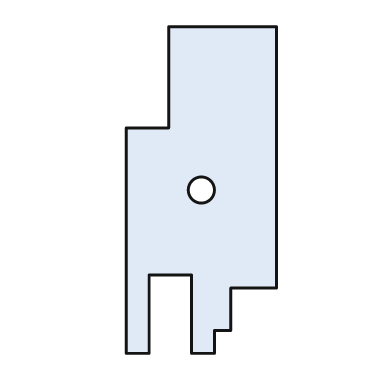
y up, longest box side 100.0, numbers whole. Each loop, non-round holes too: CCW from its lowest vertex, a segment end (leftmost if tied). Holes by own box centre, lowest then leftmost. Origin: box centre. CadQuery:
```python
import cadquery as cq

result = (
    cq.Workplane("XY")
    .moveTo(-23.0, -50.0)
    .lineTo(-16.0, -50.0)
    .lineTo(-16.0, -26.0)
    .lineTo(-3.0, -26.0)
    .lineTo(-3.0, -50.0)
    .lineTo(4.0, -50.0)
    .lineTo(4.0, -43.0)
    .lineTo(9.0, -43.0)
    .lineTo(9.0, -30.0)
    .lineTo(23.0, -30.0)
    .lineTo(23.0, 50.0)
    .lineTo(-10.0, 50.0)
    .lineTo(-10.0, 19.0)
    .lineTo(-23.0, 19.0)
    .close()
    .moveTo(0.0, 0.0)
    .circle(4.0)
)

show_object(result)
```